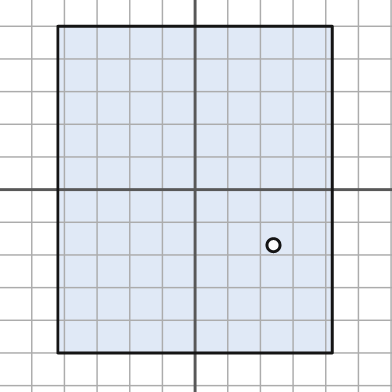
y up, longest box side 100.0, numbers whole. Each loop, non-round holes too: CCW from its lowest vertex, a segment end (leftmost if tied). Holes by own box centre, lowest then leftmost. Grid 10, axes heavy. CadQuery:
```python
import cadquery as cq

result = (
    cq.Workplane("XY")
    .moveTo(-42.0, -50.0)
    .lineTo(42.0, -50.0)
    .lineTo(42.0, 50.0)
    .lineTo(-42.0, 50.0)
    .close()
    .moveTo(24.0, -17.0)
    .circle(2.0)
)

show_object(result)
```